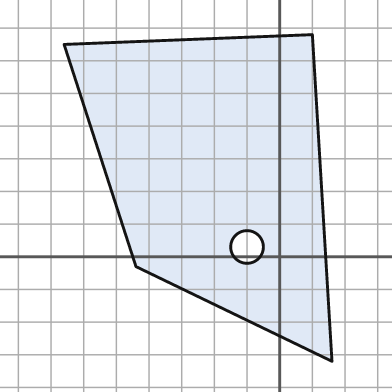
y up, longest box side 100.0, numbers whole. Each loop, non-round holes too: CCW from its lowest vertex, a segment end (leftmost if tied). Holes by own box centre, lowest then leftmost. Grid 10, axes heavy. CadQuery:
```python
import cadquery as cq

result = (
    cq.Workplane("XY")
    .moveTo(16.0, -32.0)
    .lineTo(10.0, 68.0)
    .lineTo(-66.0, 65.0)
    .lineTo(-44.0, -3.0)
    .close()
    .moveTo(-10.0, 3.0)
    .circle(5.0)
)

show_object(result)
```